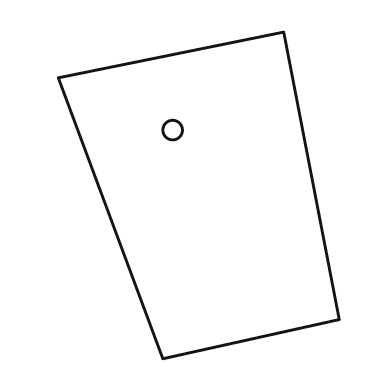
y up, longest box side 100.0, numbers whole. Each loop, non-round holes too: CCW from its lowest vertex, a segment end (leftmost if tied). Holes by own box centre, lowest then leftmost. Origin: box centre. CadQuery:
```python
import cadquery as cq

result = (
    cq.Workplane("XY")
    .moveTo(-11.0, -50.0)
    .lineTo(43.0, -38.0)
    .lineTo(26.0, 50.0)
    .lineTo(-43.0, 36.0)
    .close()
    .moveTo(-8.0, 20.0)
    .circle(3.0)
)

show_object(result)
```